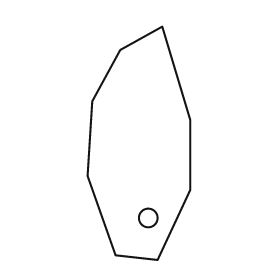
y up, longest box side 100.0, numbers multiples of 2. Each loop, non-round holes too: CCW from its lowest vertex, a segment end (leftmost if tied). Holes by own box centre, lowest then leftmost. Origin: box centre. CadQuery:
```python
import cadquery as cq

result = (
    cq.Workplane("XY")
    .moveTo(8.0, -50.0)
    .lineTo(22.0, -20.0)
    .lineTo(22.0, 10.0)
    .lineTo(10.0, 50.0)
    .lineTo(-8.0, 40.0)
    .lineTo(-20.0, 18.0)
    .lineTo(-22.0, -14.0)
    .lineTo(-10.0, -48.0)
    .close()
    .moveTo(4.0, -32.0)
    .circle(4.0)
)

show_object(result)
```